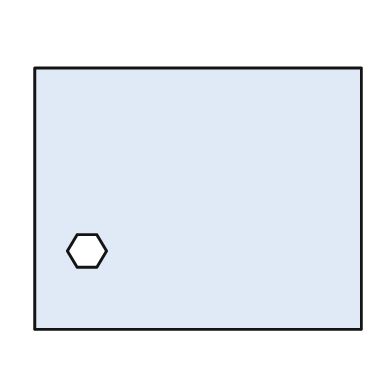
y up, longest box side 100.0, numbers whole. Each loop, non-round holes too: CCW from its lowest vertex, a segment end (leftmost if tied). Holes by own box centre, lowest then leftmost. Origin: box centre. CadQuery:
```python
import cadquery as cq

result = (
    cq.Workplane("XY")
    .moveTo(-50.0, -40.0)
    .lineTo(50.0, -40.0)
    .lineTo(50.0, 40.0)
    .lineTo(-50.0, 40.0)
    .close()
    .moveTo(-37.0, -21.0)
    .lineTo(-31.0, -21.0)
    .lineTo(-28.0, -16.0)
    .lineTo(-31.0, -11.0)
    .lineTo(-37.0, -11.0)
    .lineTo(-40.0, -16.0)
    .close()
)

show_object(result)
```